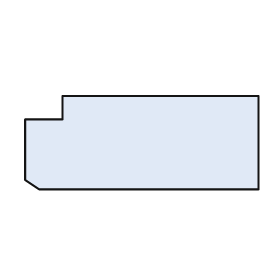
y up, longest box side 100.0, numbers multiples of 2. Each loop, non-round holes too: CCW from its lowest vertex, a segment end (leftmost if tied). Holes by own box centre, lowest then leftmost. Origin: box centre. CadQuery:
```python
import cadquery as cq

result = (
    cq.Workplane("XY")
    .moveTo(-44.0, -20.0)
    .lineTo(50.0, -20.0)
    .lineTo(50.0, 20.0)
    .lineTo(-34.0, 20.0)
    .lineTo(-34.0, 10.0)
    .lineTo(-50.0, 10.0)
    .lineTo(-50.0, -16.0)
    .close()
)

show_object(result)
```